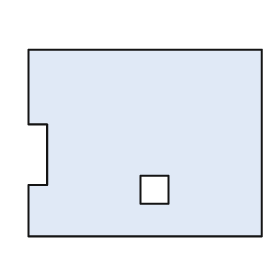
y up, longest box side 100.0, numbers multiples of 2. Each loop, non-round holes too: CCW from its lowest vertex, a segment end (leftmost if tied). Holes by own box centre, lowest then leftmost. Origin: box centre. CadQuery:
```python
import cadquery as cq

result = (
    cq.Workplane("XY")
    .moveTo(-50.0, -40.0)
    .lineTo(50.0, -40.0)
    .lineTo(50.0, 40.0)
    .lineTo(-50.0, 40.0)
    .lineTo(-50.0, 8.0)
    .lineTo(-42.0, 8.0)
    .lineTo(-42.0, -18.0)
    .lineTo(-50.0, -18.0)
    .close()
    .moveTo(-2.0, -26.0)
    .lineTo(10.0, -26.0)
    .lineTo(10.0, -14.0)
    .lineTo(-2.0, -14.0)
    .close()
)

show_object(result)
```